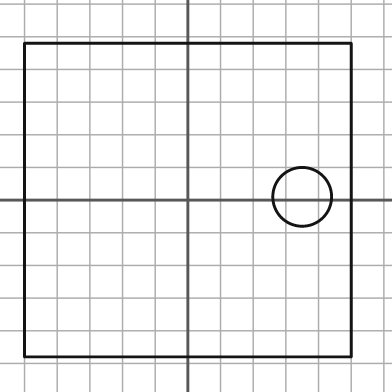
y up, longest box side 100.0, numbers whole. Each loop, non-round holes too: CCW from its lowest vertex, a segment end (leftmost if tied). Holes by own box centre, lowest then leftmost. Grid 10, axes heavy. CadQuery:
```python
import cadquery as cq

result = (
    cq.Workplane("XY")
    .moveTo(-50.0, -48.0)
    .lineTo(50.0, -48.0)
    .lineTo(50.0, 48.0)
    .lineTo(-50.0, 48.0)
    .close()
    .moveTo(35.0, 1.0)
    .circle(9.0)
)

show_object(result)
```